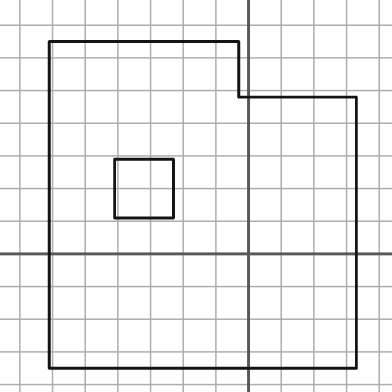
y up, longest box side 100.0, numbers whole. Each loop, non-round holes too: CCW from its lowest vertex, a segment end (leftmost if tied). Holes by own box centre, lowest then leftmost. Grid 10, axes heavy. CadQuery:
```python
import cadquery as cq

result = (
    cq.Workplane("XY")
    .moveTo(-61.0, -35.0)
    .lineTo(33.0, -35.0)
    .lineTo(33.0, 48.0)
    .lineTo(-3.0, 48.0)
    .lineTo(-3.0, 65.0)
    .lineTo(-61.0, 65.0)
    .close()
    .moveTo(-41.0, 11.0)
    .lineTo(-23.0, 11.0)
    .lineTo(-23.0, 29.0)
    .lineTo(-41.0, 29.0)
    .close()
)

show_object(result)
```